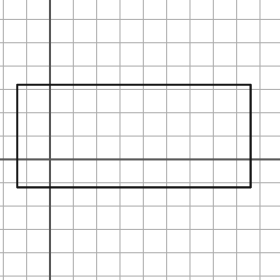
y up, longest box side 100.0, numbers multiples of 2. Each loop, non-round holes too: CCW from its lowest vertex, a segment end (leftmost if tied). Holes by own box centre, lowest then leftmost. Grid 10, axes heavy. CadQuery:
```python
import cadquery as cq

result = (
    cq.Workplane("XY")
    .moveTo(-14.0, -12.0)
    .lineTo(86.0, -12.0)
    .lineTo(86.0, 32.0)
    .lineTo(-14.0, 32.0)
    .close()
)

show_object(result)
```